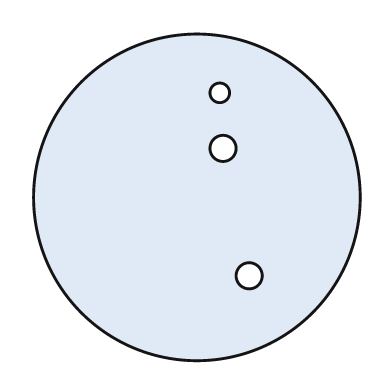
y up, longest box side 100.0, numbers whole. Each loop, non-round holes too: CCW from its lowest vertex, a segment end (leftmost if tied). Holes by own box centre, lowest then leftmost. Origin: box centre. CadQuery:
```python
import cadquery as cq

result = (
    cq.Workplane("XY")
    .moveTo(0.0, 0.0)
    .circle(50.0)
    .moveTo(16.0, -24.0)
    .circle(4.0)
    .moveTo(8.0, 15.0)
    .circle(4.0)
    .moveTo(7.0, 32.0)
    .circle(3.0)
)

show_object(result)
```